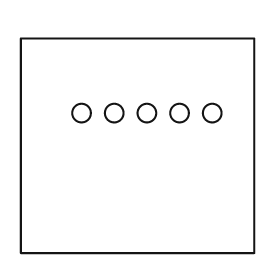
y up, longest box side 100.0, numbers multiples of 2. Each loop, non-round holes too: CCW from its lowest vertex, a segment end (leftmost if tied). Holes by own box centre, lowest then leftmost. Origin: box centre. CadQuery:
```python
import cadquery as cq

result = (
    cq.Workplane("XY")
    .moveTo(-50.0, -46.0)
    .lineTo(50.0, -46.0)
    .lineTo(50.0, 46.0)
    .lineTo(-50.0, 46.0)
    .close()
    .moveTo(-24.0, 14.0)
    .circle(4.0)
    .moveTo(-10.0, 14.0)
    .circle(4.0)
    .moveTo(4.0, 14.0)
    .circle(4.0)
    .moveTo(18.0, 14.0)
    .circle(4.0)
    .moveTo(32.0, 14.0)
    .circle(4.0)
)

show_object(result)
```